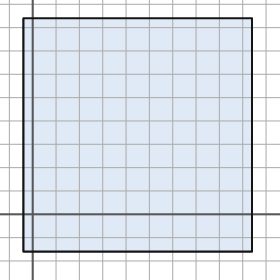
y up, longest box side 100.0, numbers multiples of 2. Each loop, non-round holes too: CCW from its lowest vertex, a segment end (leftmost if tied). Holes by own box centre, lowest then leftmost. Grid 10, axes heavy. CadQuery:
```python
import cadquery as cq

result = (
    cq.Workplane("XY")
    .moveTo(-4.0, -16.0)
    .lineTo(94.0, -16.0)
    .lineTo(94.0, 84.0)
    .lineTo(-4.0, 84.0)
    .close()
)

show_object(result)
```